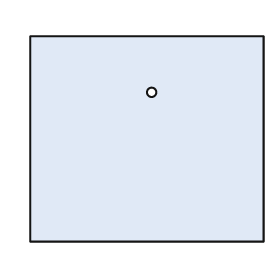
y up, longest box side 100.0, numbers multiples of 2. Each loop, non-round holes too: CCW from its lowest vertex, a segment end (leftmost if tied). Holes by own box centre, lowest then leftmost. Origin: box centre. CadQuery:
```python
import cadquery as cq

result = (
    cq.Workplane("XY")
    .moveTo(-50.0, -44.0)
    .lineTo(50.0, -44.0)
    .lineTo(50.0, 44.0)
    .lineTo(-50.0, 44.0)
    .close()
    .moveTo(2.0, 20.0)
    .circle(2.0)
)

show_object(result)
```